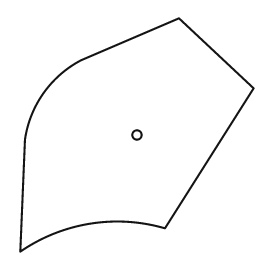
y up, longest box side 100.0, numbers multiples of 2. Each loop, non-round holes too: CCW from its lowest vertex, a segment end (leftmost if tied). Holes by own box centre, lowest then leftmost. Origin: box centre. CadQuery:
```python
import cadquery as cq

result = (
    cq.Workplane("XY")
    .moveTo(-50.0, -50.0)
    .threePointArc((-20.0, -38.0), (12.0, -40.0))
    .lineTo(50.0, 20.0)
    .lineTo(18.0, 50.0)
    .lineTo(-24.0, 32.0)
    .threePointArc((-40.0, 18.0), (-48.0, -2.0))
    .close()
    .moveTo(0.0, 0.0)
    .circle(2.0)
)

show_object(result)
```